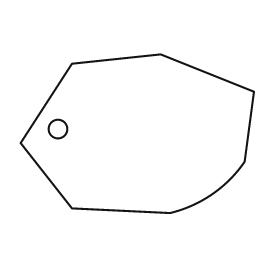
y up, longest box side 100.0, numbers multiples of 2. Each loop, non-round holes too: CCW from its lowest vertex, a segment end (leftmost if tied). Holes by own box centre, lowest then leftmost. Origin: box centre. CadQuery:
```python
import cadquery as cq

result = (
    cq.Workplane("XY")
    .moveTo(14.0, -34.0)
    .threePointArc((32.0, -26.0), (46.0, -12.0))
    .lineTo(50.0, 18.0)
    .lineTo(10.0, 34.0)
    .lineTo(-28.0, 30.0)
    .lineTo(-50.0, -4.0)
    .lineTo(-28.0, -32.0)
    .close()
    .moveTo(-34.0, 2.0)
    .circle(4.0)
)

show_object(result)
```